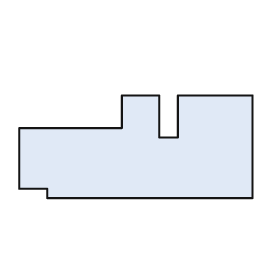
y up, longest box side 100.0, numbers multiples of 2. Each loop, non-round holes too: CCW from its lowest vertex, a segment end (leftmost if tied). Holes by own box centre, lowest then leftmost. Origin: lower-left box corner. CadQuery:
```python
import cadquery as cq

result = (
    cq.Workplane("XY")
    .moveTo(12.0, 0.0)
    .lineTo(100.0, 0.0)
    .lineTo(100.0, 44.0)
    .lineTo(68.0, 44.0)
    .lineTo(68.0, 26.0)
    .lineTo(60.0, 26.0)
    .lineTo(60.0, 44.0)
    .lineTo(44.0, 44.0)
    .lineTo(44.0, 30.0)
    .lineTo(0.0, 30.0)
    .lineTo(0.0, 4.0)
    .lineTo(12.0, 4.0)
    .close()
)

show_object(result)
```